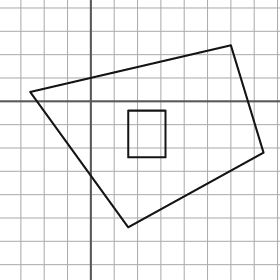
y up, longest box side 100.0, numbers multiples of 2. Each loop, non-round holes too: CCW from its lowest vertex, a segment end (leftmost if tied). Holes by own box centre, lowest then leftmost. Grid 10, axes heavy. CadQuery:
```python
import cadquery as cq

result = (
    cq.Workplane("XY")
    .moveTo(16.0, -54.0)
    .lineTo(74.0, -22.0)
    .lineTo(60.0, 24.0)
    .lineTo(-26.0, 4.0)
    .close()
    .moveTo(16.0, -24.0)
    .lineTo(32.0, -24.0)
    .lineTo(32.0, -4.0)
    .lineTo(16.0, -4.0)
    .close()
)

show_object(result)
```